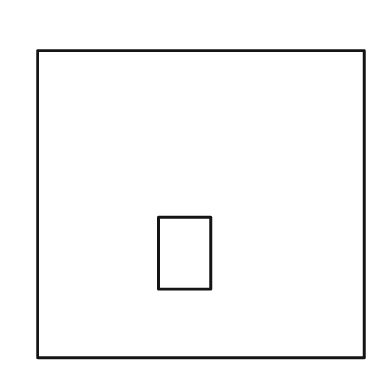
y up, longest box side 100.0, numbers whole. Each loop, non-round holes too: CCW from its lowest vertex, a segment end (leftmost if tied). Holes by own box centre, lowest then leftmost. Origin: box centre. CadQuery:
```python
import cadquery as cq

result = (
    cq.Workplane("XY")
    .moveTo(-50.0, -47.0)
    .lineTo(50.0, -47.0)
    .lineTo(50.0, 47.0)
    .lineTo(-50.0, 47.0)
    .close()
    .moveTo(-13.0, -26.0)
    .lineTo(3.0, -26.0)
    .lineTo(3.0, -4.0)
    .lineTo(-13.0, -4.0)
    .close()
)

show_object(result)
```